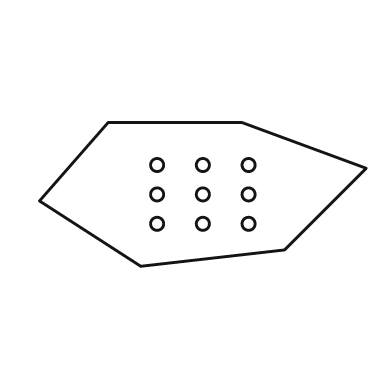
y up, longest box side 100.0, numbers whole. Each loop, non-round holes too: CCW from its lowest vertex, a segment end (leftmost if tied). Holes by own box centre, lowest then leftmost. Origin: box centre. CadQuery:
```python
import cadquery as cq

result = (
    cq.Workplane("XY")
    .moveTo(-19.0, -22.0)
    .lineTo(25.0, -17.0)
    .lineTo(50.0, 8.0)
    .lineTo(12.0, 22.0)
    .lineTo(-29.0, 22.0)
    .lineTo(-50.0, -2.0)
    .close()
    .moveTo(-14.0, -9.0)
    .circle(2.0)
    .moveTo(0.0, -9.0)
    .circle(2.0)
    .moveTo(14.0, -9.0)
    .circle(2.0)
    .moveTo(-14.0, 0.0)
    .circle(2.0)
    .moveTo(0.0, 0.0)
    .circle(2.0)
    .moveTo(14.0, 0.0)
    .circle(2.0)
    .moveTo(-14.0, 9.0)
    .circle(2.0)
    .moveTo(0.0, 9.0)
    .circle(2.0)
    .moveTo(14.0, 9.0)
    .circle(2.0)
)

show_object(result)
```